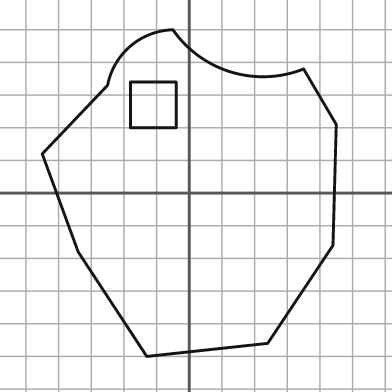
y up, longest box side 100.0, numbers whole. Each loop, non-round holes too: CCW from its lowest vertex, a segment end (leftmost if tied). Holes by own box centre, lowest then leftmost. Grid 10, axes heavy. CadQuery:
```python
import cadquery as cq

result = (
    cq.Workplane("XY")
    .moveTo(-13.0, -50.0)
    .lineTo(24.0, -46.0)
    .lineTo(44.0, -16.0)
    .lineTo(45.0, 21.0)
    .lineTo(35.0, 38.0)
    .threePointArc((13.0, 37.0), (-5.0, 50.0))
    .threePointArc((-18.0, 45.0), (-25.0, 33.0))
    .lineTo(-45.0, 12.0)
    .lineTo(-34.0, -18.0)
    .close()
    .moveTo(-18.0, 20.0)
    .lineTo(-4.0, 20.0)
    .lineTo(-4.0, 34.0)
    .lineTo(-18.0, 34.0)
    .close()
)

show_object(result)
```